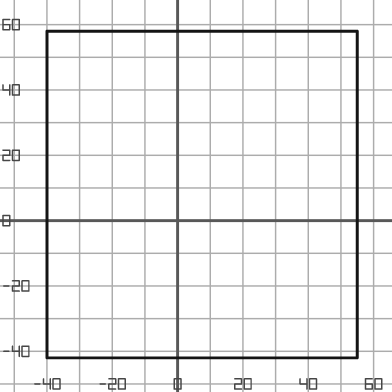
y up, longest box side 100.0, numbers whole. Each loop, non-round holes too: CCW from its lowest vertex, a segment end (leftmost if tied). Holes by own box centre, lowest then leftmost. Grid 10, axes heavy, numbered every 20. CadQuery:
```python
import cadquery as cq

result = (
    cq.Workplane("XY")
    .moveTo(-40.0, -42.0)
    .lineTo(55.0, -42.0)
    .lineTo(55.0, 58.0)
    .lineTo(-40.0, 58.0)
    .close()
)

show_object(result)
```